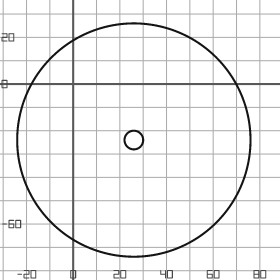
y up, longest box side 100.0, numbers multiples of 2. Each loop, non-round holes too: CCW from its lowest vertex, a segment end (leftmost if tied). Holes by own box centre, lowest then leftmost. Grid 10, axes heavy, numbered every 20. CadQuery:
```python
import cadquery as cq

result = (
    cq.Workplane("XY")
    .moveTo(26.0, -24.0)
    .circle(50.0)
    .moveTo(26.0, -24.0)
    .circle(4.0)
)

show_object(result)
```